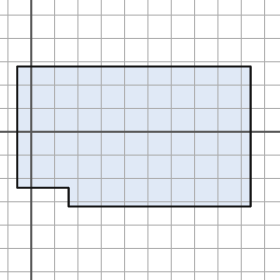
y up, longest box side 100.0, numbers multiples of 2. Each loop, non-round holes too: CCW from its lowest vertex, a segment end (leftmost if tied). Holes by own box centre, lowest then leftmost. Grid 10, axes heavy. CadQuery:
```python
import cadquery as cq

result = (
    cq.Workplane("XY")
    .moveTo(16.0, -32.0)
    .lineTo(94.0, -32.0)
    .lineTo(94.0, 28.0)
    .lineTo(-6.0, 28.0)
    .lineTo(-6.0, -24.0)
    .lineTo(16.0, -24.0)
    .close()
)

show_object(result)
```